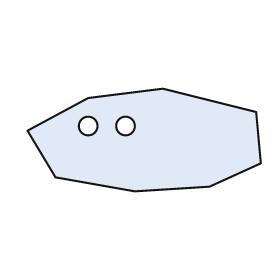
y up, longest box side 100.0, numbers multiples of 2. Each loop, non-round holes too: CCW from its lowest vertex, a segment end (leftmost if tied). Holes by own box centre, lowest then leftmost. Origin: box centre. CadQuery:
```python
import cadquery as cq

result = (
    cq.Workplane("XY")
    .moveTo(-4.0, -22.0)
    .lineTo(28.0, -20.0)
    .lineTo(50.0, -10.0)
    .lineTo(48.0, 12.0)
    .lineTo(8.0, 22.0)
    .lineTo(-24.0, 18.0)
    .lineTo(-50.0, 4.0)
    .lineTo(-38.0, -16.0)
    .close()
    .moveTo(-24.0, 6.0)
    .circle(4.0)
    .moveTo(-8.0, 6.0)
    .circle(4.0)
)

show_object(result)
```